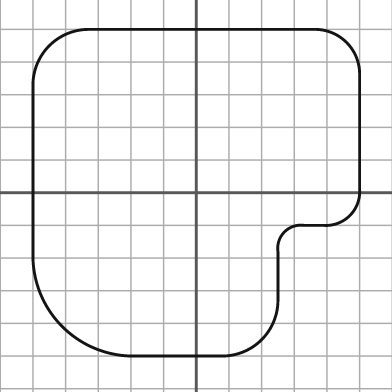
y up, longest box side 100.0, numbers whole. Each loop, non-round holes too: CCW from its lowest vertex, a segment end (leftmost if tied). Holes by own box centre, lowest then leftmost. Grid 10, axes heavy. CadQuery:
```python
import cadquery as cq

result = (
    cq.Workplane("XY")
    .moveTo(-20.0, -50.0)
    .lineTo(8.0, -50.0)
    .threePointArc((20.0, -45.0), (25.0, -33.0))
    .lineTo(25.0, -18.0)
    .threePointArc((27.0, -12.0), (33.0, -10.0))
    .lineTo(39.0, -10.0)
    .threePointArc((47.0, -7.0), (50.0, 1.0))
    .lineTo(50.0, 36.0)
    .threePointArc((46.0, 46.0), (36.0, 50.0))
    .lineTo(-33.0, 50.0)
    .threePointArc((-45.0, 45.0), (-50.0, 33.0))
    .lineTo(-50.0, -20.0)
    .threePointArc((-41.0, -41.0), (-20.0, -50.0))
    .close()
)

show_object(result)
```